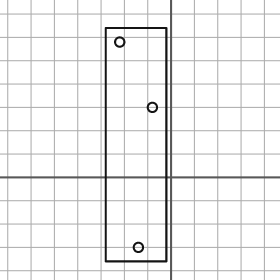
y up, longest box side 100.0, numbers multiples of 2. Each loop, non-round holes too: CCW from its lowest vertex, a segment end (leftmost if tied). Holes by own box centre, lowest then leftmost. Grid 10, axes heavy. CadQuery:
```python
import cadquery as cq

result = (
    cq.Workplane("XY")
    .moveTo(-28.0, -36.0)
    .lineTo(-2.0, -36.0)
    .lineTo(-2.0, 64.0)
    .lineTo(-28.0, 64.0)
    .close()
    .moveTo(-14.0, -30.0)
    .circle(2.0)
    .moveTo(-8.0, 30.0)
    .circle(2.0)
    .moveTo(-22.0, 58.0)
    .circle(2.0)
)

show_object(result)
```